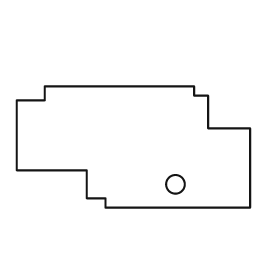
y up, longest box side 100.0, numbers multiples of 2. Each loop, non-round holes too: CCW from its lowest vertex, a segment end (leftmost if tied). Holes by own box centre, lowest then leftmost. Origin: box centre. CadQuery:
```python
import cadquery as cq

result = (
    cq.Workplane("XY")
    .moveTo(-12.0, -26.0)
    .lineTo(50.0, -26.0)
    .lineTo(50.0, 8.0)
    .lineTo(32.0, 8.0)
    .lineTo(32.0, 22.0)
    .lineTo(26.0, 22.0)
    .lineTo(26.0, 26.0)
    .lineTo(-38.0, 26.0)
    .lineTo(-38.0, 20.0)
    .lineTo(-50.0, 20.0)
    .lineTo(-50.0, -10.0)
    .lineTo(-20.0, -10.0)
    .lineTo(-20.0, -22.0)
    .lineTo(-12.0, -22.0)
    .close()
    .moveTo(18.0, -16.0)
    .circle(4.0)
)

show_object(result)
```